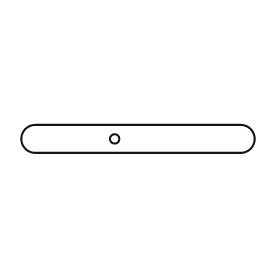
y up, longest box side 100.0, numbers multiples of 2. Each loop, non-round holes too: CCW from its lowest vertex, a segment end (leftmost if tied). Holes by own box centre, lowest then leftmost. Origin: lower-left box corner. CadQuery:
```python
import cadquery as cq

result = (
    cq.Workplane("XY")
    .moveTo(6.0, 0.0)
    .lineTo(94.0, 0.0)
    .threePointArc((100.0, 6.0), (94.0, 12.0))
    .lineTo(6.0, 12.0)
    .threePointArc((0.0, 6.0), (6.0, 0.0))
    .close()
    .moveTo(40.0, 6.0)
    .circle(2.0)
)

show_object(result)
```